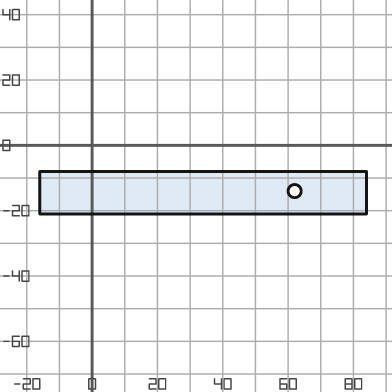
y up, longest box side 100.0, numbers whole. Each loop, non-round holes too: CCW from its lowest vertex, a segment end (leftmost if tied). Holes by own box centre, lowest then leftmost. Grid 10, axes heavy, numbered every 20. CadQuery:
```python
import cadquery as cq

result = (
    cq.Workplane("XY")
    .moveTo(-16.0, -21.0)
    .lineTo(84.0, -21.0)
    .lineTo(84.0, -8.0)
    .lineTo(-16.0, -8.0)
    .close()
    .moveTo(62.0, -14.0)
    .circle(2.0)
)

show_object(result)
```